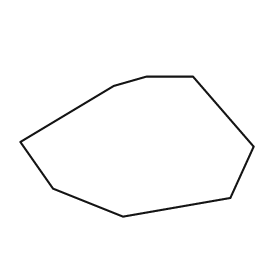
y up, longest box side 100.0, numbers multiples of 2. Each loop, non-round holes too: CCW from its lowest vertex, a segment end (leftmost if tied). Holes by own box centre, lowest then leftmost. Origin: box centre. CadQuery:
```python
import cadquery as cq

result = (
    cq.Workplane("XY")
    .moveTo(-6.0, -30.0)
    .lineTo(40.0, -22.0)
    .lineTo(50.0, 0.0)
    .lineTo(24.0, 30.0)
    .lineTo(4.0, 30.0)
    .lineTo(-10.0, 26.0)
    .lineTo(-50.0, 2.0)
    .lineTo(-36.0, -18.0)
    .close()
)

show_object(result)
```